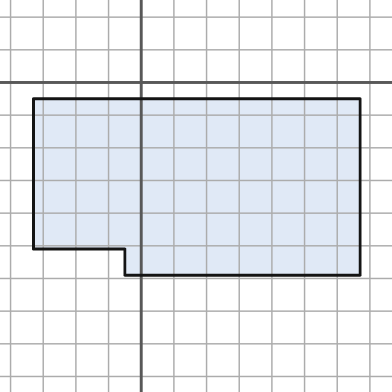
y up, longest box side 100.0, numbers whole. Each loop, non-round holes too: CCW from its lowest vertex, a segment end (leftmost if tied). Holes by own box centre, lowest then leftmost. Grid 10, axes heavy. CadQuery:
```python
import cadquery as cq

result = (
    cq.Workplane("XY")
    .moveTo(-5.0, -59.0)
    .lineTo(67.0, -59.0)
    .lineTo(67.0, -5.0)
    .lineTo(-33.0, -5.0)
    .lineTo(-33.0, -51.0)
    .lineTo(-5.0, -51.0)
    .close()
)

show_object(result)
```